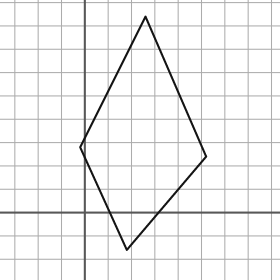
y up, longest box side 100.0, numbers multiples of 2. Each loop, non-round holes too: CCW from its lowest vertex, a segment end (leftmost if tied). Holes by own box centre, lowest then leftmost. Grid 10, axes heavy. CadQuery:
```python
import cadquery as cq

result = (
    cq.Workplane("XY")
    .moveTo(18.0, -16.0)
    .lineTo(52.0, 24.0)
    .lineTo(26.0, 84.0)
    .lineTo(-2.0, 28.0)
    .close()
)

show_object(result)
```